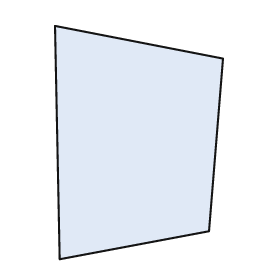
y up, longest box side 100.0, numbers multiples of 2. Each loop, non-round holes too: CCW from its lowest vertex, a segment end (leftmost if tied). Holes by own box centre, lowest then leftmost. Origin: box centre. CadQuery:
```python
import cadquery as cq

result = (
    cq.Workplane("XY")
    .moveTo(-34.0, -50.0)
    .lineTo(30.0, -38.0)
    .lineTo(36.0, 36.0)
    .lineTo(-36.0, 50.0)
    .close()
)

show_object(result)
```